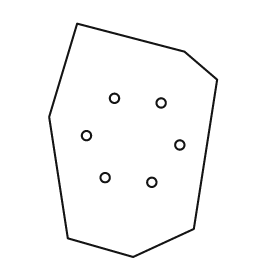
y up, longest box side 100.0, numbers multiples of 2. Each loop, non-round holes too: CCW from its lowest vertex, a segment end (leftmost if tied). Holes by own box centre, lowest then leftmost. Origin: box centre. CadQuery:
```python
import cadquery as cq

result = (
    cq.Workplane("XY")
    .moveTo(0.0, -50.0)
    .lineTo(26.0, -38.0)
    .lineTo(36.0, 26.0)
    .lineTo(22.0, 38.0)
    .lineTo(-24.0, 50.0)
    .lineTo(-36.0, 10.0)
    .lineTo(-28.0, -42.0)
    .close()
    .moveTo(8.0, -18.0)
    .circle(2.0)
    .moveTo(-12.0, -16.0)
    .circle(2.0)
    .moveTo(20.0, -2.0)
    .circle(2.0)
    .moveTo(-20.0, 2.0)
    .circle(2.0)
    .moveTo(12.0, 16.0)
    .circle(2.0)
    .moveTo(-8.0, 18.0)
    .circle(2.0)
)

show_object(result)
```